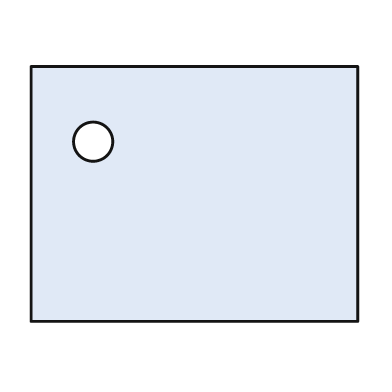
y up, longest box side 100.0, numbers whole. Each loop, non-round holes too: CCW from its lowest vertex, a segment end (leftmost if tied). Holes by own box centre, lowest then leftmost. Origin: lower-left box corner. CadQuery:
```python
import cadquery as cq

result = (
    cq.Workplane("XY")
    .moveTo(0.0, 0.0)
    .lineTo(100.0, 0.0)
    .lineTo(100.0, 78.0)
    .lineTo(0.0, 78.0)
    .close()
    .moveTo(19.0, 55.0)
    .circle(6.0)
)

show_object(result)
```